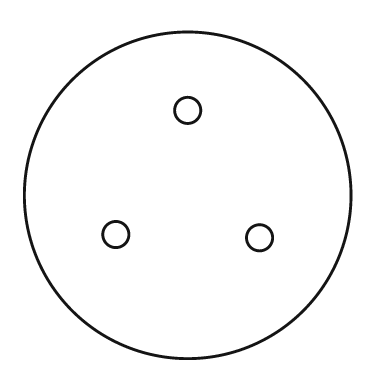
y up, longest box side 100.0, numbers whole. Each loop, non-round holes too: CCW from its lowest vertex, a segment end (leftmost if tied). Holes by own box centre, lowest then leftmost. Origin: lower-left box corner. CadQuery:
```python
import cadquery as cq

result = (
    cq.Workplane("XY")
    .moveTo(50.0, 50.0)
    .circle(50.0)
    .moveTo(72.0, 37.0)
    .circle(4.0)
    .moveTo(28.0, 38.0)
    .circle(4.0)
    .moveTo(50.0, 76.0)
    .circle(4.0)
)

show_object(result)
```